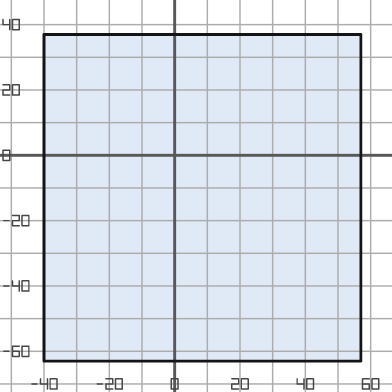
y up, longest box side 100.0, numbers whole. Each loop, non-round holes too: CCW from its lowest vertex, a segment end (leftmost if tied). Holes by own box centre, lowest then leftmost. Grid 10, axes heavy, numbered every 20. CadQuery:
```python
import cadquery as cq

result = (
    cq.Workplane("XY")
    .moveTo(-40.0, -63.0)
    .lineTo(57.0, -63.0)
    .lineTo(57.0, 37.0)
    .lineTo(-40.0, 37.0)
    .close()
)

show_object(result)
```